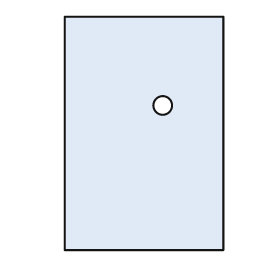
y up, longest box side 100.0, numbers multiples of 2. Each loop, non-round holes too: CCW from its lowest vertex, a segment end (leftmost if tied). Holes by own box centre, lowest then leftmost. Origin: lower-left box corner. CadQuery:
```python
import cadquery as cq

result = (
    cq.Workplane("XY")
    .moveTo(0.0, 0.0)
    .lineTo(68.0, 0.0)
    .lineTo(68.0, 100.0)
    .lineTo(0.0, 100.0)
    .close()
    .moveTo(42.0, 62.0)
    .circle(4.0)
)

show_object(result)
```